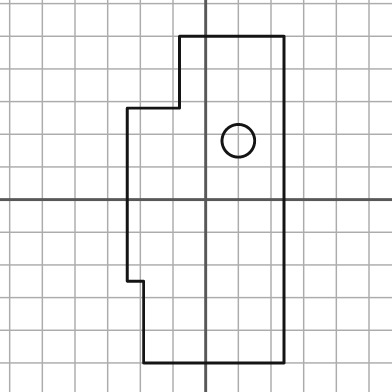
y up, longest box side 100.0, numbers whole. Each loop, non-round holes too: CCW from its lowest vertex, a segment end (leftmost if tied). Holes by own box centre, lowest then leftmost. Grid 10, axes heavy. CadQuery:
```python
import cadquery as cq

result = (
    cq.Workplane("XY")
    .moveTo(-19.0, -50.0)
    .lineTo(24.0, -50.0)
    .lineTo(24.0, 50.0)
    .lineTo(-8.0, 50.0)
    .lineTo(-8.0, 28.0)
    .lineTo(-24.0, 28.0)
    .lineTo(-24.0, -25.0)
    .lineTo(-19.0, -25.0)
    .close()
    .moveTo(10.0, 18.0)
    .circle(5.0)
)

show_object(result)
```